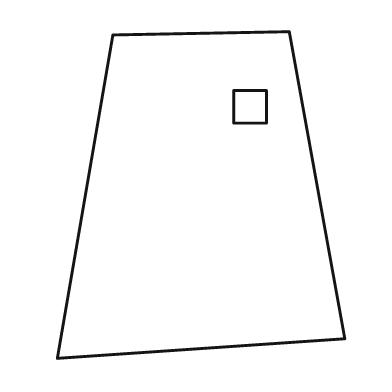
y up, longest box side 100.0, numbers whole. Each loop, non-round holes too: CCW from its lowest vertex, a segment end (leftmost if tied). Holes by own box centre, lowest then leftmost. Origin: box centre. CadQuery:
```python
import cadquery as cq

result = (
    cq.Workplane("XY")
    .moveTo(-44.0, -50.0)
    .lineTo(44.0, -44.0)
    .lineTo(27.0, 50.0)
    .lineTo(-27.0, 49.0)
    .close()
    .moveTo(10.0, 22.0)
    .lineTo(20.0, 22.0)
    .lineTo(20.0, 32.0)
    .lineTo(10.0, 32.0)
    .close()
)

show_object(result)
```